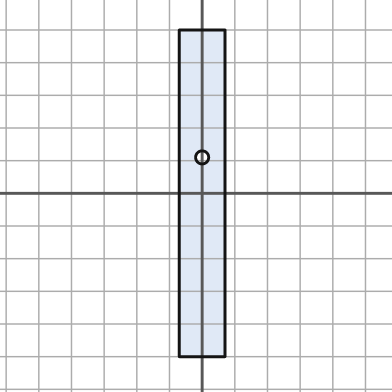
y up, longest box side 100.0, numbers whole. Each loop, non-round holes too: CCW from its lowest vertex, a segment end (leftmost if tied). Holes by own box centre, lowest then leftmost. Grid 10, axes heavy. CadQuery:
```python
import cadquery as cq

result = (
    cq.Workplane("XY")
    .moveTo(-7.0, -50.0)
    .lineTo(7.0, -50.0)
    .lineTo(7.0, 50.0)
    .lineTo(-7.0, 50.0)
    .close()
    .moveTo(0.0, 11.0)
    .circle(2.0)
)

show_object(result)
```